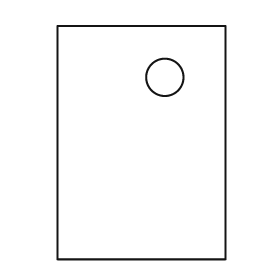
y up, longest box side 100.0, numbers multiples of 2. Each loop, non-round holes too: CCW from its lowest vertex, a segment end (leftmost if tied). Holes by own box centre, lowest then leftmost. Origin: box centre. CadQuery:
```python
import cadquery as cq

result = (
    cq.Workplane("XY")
    .moveTo(-36.0, -50.0)
    .lineTo(36.0, -50.0)
    .lineTo(36.0, 50.0)
    .lineTo(-36.0, 50.0)
    .close()
    .moveTo(10.0, 28.0)
    .circle(8.0)
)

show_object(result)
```